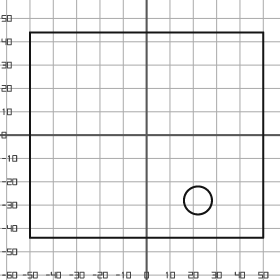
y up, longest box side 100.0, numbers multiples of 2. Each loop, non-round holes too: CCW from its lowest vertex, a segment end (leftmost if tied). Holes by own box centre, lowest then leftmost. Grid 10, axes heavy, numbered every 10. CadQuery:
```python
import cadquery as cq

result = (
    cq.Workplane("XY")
    .moveTo(-50.0, -44.0)
    .lineTo(50.0, -44.0)
    .lineTo(50.0, 44.0)
    .lineTo(-50.0, 44.0)
    .close()
    .moveTo(22.0, -28.0)
    .circle(6.0)
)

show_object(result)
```